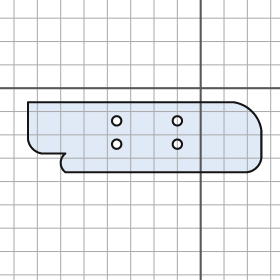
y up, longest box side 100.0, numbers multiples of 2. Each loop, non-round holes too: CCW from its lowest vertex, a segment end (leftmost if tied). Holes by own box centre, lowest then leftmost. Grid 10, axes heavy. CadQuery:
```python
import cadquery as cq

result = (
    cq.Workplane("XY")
    .moveTo(-58.0, -36.0)
    .lineTo(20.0, -36.0)
    .threePointArc((24.0, -34.0), (26.0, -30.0))
    .lineTo(26.0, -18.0)
    .threePointArc((22.0, -10.0), (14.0, -6.0))
    .lineTo(-74.0, -6.0)
    .lineTo(-74.0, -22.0)
    .threePointArc((-72.0, -26.0), (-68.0, -28.0))
    .lineTo(-58.0, -28.0)
    .threePointArc((-60.0, -32.0), (-58.0, -36.0))
    .close()
    .moveTo(-36.0, -24.0)
    .circle(2.0)
    .moveTo(-10.0, -24.0)
    .circle(2.0)
    .moveTo(-36.0, -14.0)
    .circle(2.0)
    .moveTo(-10.0, -14.0)
    .circle(2.0)
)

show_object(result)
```